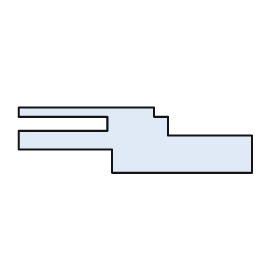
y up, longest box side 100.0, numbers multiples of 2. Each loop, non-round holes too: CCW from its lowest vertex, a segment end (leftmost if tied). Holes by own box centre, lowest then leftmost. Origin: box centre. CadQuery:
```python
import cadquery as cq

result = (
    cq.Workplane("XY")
    .moveTo(-10.0, -14.0)
    .lineTo(50.0, -14.0)
    .lineTo(50.0, 2.0)
    .lineTo(14.0, 2.0)
    .lineTo(14.0, 10.0)
    .lineTo(8.0, 10.0)
    .lineTo(8.0, 14.0)
    .lineTo(-50.0, 14.0)
    .lineTo(-50.0, 10.0)
    .lineTo(-12.0, 10.0)
    .lineTo(-12.0, 4.0)
    .lineTo(-50.0, 4.0)
    .lineTo(-50.0, -4.0)
    .lineTo(-10.0, -4.0)
    .close()
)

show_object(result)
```